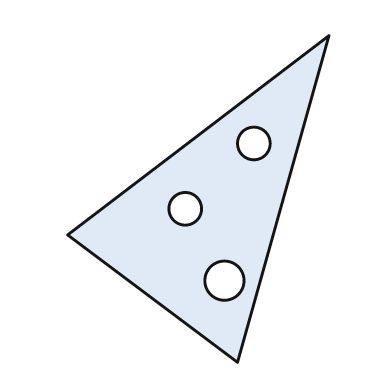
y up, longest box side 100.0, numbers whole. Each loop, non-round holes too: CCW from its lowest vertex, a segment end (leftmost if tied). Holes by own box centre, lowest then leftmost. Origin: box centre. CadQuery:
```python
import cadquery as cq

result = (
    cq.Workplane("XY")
    .moveTo(12.0, -50.0)
    .lineTo(40.0, 50.0)
    .lineTo(-40.0, -11.0)
    .close()
    .moveTo(8.0, -25.0)
    .circle(6.0)
    .moveTo(-4.0, -3.0)
    .circle(5.0)
    .moveTo(17.0, 17.0)
    .circle(5.0)
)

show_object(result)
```